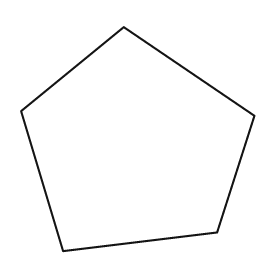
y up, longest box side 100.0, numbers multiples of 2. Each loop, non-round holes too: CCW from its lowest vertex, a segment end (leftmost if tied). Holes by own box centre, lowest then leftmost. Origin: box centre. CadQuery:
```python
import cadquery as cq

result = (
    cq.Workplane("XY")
    .moveTo(-32.0, -48.0)
    .lineTo(34.0, -40.0)
    .lineTo(50.0, 10.0)
    .lineTo(-6.0, 48.0)
    .lineTo(-50.0, 12.0)
    .close()
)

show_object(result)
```